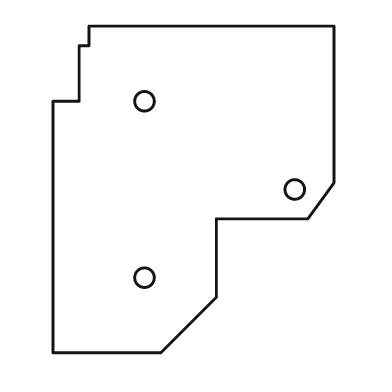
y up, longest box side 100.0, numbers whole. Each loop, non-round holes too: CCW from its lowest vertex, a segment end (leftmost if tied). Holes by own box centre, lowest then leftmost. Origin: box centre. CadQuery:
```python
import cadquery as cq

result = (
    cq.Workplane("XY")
    .moveTo(-43.0, -50.0)
    .lineTo(-10.0, -50.0)
    .lineTo(7.0, -33.0)
    .lineTo(7.0, -9.0)
    .lineTo(35.0, -9.0)
    .lineTo(43.0, 2.0)
    .lineTo(43.0, 50.0)
    .lineTo(-32.0, 50.0)
    .lineTo(-32.0, 44.0)
    .lineTo(-35.0, 44.0)
    .lineTo(-35.0, 27.0)
    .lineTo(-43.0, 27.0)
    .close()
    .moveTo(-15.0, -27.0)
    .circle(3.0)
    .moveTo(31.0, 0.0)
    .circle(3.0)
    .moveTo(-15.0, 27.0)
    .circle(3.0)
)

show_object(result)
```